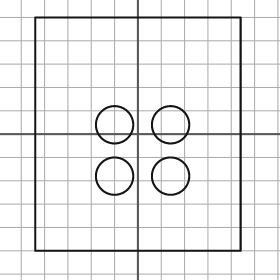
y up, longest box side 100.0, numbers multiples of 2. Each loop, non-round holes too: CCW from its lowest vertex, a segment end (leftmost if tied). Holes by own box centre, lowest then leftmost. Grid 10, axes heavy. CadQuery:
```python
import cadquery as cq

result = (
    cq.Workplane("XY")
    .moveTo(-44.0, -50.0)
    .lineTo(44.0, -50.0)
    .lineTo(44.0, 50.0)
    .lineTo(-44.0, 50.0)
    .close()
    .moveTo(-10.0, -18.0)
    .circle(8.0)
    .moveTo(14.0, -18.0)
    .circle(8.0)
    .moveTo(-10.0, 4.0)
    .circle(8.0)
    .moveTo(14.0, 4.0)
    .circle(8.0)
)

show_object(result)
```